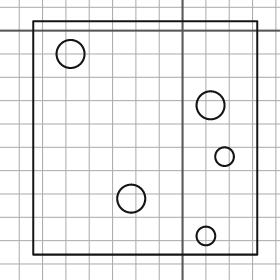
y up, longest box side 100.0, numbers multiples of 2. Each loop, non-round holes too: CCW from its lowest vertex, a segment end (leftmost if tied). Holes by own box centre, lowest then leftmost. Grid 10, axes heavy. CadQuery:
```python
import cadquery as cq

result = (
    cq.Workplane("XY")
    .moveTo(-64.0, -96.0)
    .lineTo(32.0, -96.0)
    .lineTo(32.0, 4.0)
    .lineTo(-64.0, 4.0)
    .close()
    .moveTo(10.0, -88.0)
    .circle(4.0)
    .moveTo(-22.0, -72.0)
    .circle(6.0)
    .moveTo(18.0, -54.0)
    .circle(4.0)
    .moveTo(12.0, -32.0)
    .circle(6.0)
    .moveTo(-48.0, -10.0)
    .circle(6.0)
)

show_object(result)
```